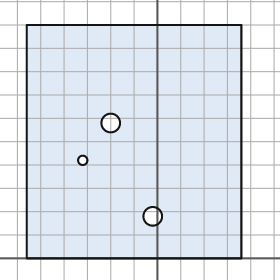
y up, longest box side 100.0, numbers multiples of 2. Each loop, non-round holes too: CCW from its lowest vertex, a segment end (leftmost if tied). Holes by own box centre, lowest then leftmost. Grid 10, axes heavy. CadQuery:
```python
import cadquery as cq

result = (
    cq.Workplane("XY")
    .moveTo(-56.0, 0.0)
    .lineTo(36.0, 0.0)
    .lineTo(36.0, 100.0)
    .lineTo(-56.0, 100.0)
    .close()
    .moveTo(-2.0, 18.0)
    .circle(4.0)
    .moveTo(-32.0, 42.0)
    .circle(2.0)
    .moveTo(-20.0, 58.0)
    .circle(4.0)
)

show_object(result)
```